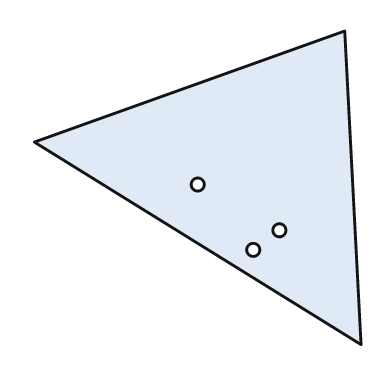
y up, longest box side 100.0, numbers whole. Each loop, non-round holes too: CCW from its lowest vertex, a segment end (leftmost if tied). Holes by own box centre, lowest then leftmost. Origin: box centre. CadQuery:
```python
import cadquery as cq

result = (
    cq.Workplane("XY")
    .moveTo(50.0, -48.0)
    .lineTo(45.0, 48.0)
    .lineTo(-50.0, 14.0)
    .close()
    .moveTo(17.0, -19.0)
    .circle(2.0)
    .moveTo(25.0, -13.0)
    .circle(2.0)
    .moveTo(0.0, 1.0)
    .circle(2.0)
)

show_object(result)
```